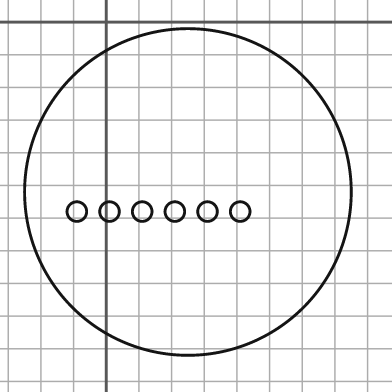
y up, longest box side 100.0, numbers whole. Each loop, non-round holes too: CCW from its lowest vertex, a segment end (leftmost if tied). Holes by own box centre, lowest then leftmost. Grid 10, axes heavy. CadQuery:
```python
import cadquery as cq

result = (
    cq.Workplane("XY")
    .moveTo(25.0, -52.0)
    .circle(50.0)
    .moveTo(-9.0, -58.0)
    .circle(3.0)
    .moveTo(1.0, -58.0)
    .circle(3.0)
    .moveTo(11.0, -58.0)
    .circle(3.0)
    .moveTo(21.0, -58.0)
    .circle(3.0)
    .moveTo(31.0, -58.0)
    .circle(3.0)
    .moveTo(41.0, -58.0)
    .circle(3.0)
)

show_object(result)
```